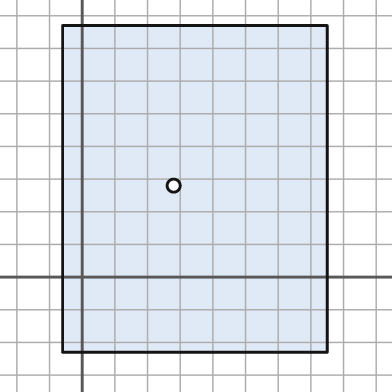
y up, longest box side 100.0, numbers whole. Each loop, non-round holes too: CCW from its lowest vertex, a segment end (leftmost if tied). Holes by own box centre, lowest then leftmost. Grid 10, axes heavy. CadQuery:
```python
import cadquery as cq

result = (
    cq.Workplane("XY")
    .moveTo(-6.0, -23.0)
    .lineTo(75.0, -23.0)
    .lineTo(75.0, 77.0)
    .lineTo(-6.0, 77.0)
    .close()
    .moveTo(28.0, 28.0)
    .circle(2.0)
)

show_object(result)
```